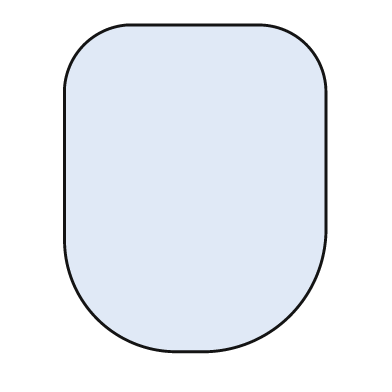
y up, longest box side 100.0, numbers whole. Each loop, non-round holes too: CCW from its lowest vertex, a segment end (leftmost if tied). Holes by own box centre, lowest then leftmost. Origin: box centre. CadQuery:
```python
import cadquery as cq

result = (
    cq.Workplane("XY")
    .moveTo(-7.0, -50.0)
    .lineTo(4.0, -50.0)
    .threePointArc((29.0, -39.0), (40.0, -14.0))
    .lineTo(40.0, 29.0)
    .threePointArc((34.0, 44.0), (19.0, 50.0))
    .lineTo(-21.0, 50.0)
    .threePointArc((-34.0, 44.0), (-40.0, 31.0))
    .lineTo(-40.0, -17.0)
    .threePointArc((-30.0, -40.0), (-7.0, -50.0))
    .close()
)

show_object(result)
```